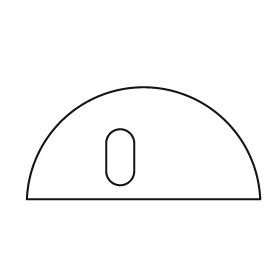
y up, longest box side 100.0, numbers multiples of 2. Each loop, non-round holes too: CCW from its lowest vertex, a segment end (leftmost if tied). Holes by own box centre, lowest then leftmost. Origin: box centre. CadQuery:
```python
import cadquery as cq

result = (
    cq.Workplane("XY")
    .moveTo(-50.0, -24.0)
    .lineTo(50.0, -24.0)
    .threePointArc((0.0, 24.0), (-50.0, -24.0))
    .close()
    .moveTo(-16.0, -12.0)
    .threePointArc((-10.0, -18.0), (-4.0, -12.0))
    .lineTo(-4.0, 0.0)
    .threePointArc((-10.0, 6.0), (-16.0, 0.0))
    .close()
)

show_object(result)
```